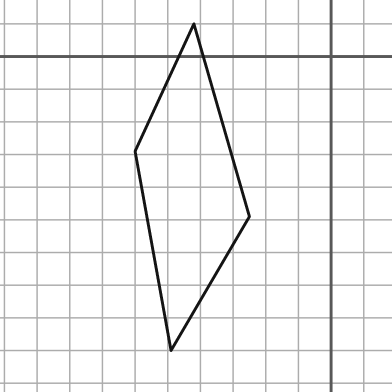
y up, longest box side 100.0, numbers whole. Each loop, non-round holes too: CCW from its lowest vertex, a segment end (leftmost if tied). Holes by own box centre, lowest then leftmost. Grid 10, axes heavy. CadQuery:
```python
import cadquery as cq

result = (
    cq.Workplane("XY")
    .moveTo(-49.0, -90.0)
    .lineTo(-25.0, -49.0)
    .lineTo(-42.0, 10.0)
    .lineTo(-60.0, -29.0)
    .close()
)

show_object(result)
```